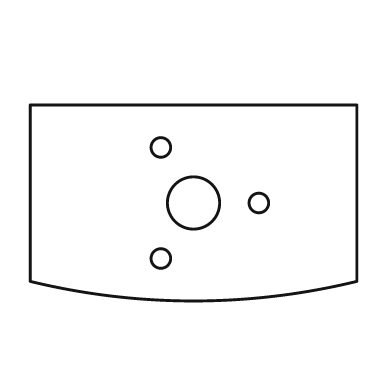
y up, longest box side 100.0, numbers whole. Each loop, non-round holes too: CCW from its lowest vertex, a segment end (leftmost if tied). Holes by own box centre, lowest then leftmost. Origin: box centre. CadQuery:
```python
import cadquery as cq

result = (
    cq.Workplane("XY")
    .moveTo(-50.0, -24.0)
    .threePointArc((0.0, -30.0), (50.0, -24.0))
    .lineTo(50.0, 30.0)
    .lineTo(-50.0, 30.0)
    .close()
    .moveTo(-10.0, -17.0)
    .circle(3.0)
    .moveTo(0.0, 0.0)
    .circle(8.0)
    .moveTo(20.0, 0.0)
    .circle(3.0)
    .moveTo(-10.0, 17.0)
    .circle(3.0)
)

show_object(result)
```